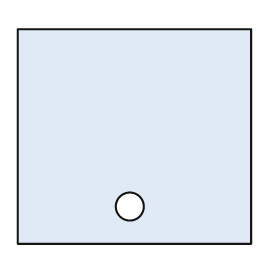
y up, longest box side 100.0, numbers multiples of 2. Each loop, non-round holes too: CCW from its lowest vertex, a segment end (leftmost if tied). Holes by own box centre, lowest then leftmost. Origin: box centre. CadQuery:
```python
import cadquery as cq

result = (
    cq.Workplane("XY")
    .moveTo(-50.0, -46.0)
    .lineTo(50.0, -46.0)
    .lineTo(50.0, 46.0)
    .lineTo(-50.0, 46.0)
    .close()
    .moveTo(-2.0, -30.0)
    .circle(6.0)
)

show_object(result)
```